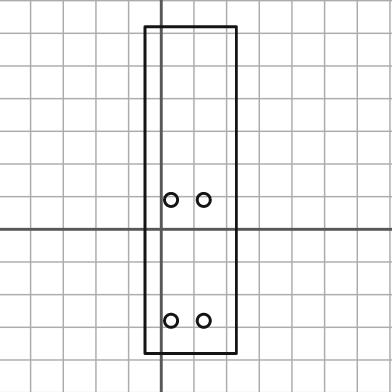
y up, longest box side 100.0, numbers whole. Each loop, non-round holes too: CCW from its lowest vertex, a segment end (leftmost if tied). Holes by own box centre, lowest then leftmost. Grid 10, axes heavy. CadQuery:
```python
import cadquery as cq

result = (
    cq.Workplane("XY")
    .moveTo(-5.0, -38.0)
    .lineTo(23.0, -38.0)
    .lineTo(23.0, 62.0)
    .lineTo(-5.0, 62.0)
    .close()
    .moveTo(3.0, -28.0)
    .circle(2.0)
    .moveTo(13.0, -28.0)
    .circle(2.0)
    .moveTo(3.0, 9.0)
    .circle(2.0)
    .moveTo(13.0, 9.0)
    .circle(2.0)
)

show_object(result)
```